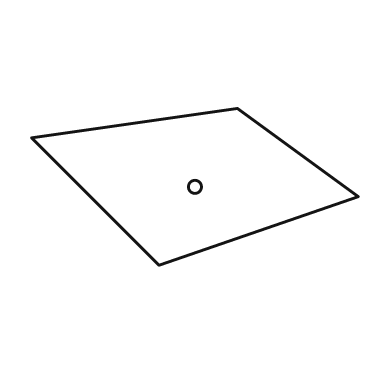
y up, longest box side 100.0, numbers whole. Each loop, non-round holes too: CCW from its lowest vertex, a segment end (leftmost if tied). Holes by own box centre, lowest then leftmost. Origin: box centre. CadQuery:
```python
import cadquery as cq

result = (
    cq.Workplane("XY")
    .moveTo(-11.0, -24.0)
    .lineTo(50.0, -3.0)
    .lineTo(13.0, 24.0)
    .lineTo(-50.0, 15.0)
    .close()
    .moveTo(0.0, 0.0)
    .circle(2.0)
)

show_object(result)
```